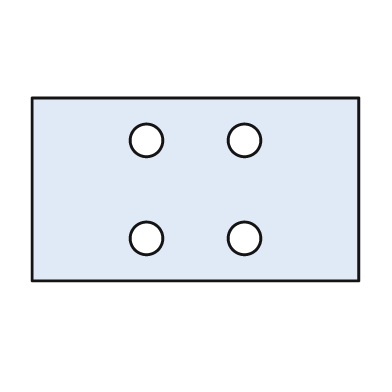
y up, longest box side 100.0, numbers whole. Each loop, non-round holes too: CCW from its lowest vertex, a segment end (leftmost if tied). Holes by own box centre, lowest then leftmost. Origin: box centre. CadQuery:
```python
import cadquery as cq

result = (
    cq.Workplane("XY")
    .moveTo(-50.0, -28.0)
    .lineTo(50.0, -28.0)
    .lineTo(50.0, 28.0)
    .lineTo(-50.0, 28.0)
    .close()
    .moveTo(-15.0, -15.0)
    .circle(5.0)
    .moveTo(15.0, -15.0)
    .circle(5.0)
    .moveTo(-15.0, 15.0)
    .circle(5.0)
    .moveTo(15.0, 15.0)
    .circle(5.0)
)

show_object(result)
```